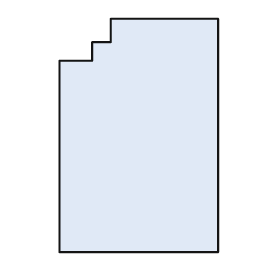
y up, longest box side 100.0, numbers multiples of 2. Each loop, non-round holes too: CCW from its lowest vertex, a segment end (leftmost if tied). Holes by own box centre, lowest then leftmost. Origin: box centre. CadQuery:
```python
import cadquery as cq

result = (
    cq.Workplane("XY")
    .moveTo(-34.0, -50.0)
    .lineTo(34.0, -50.0)
    .lineTo(34.0, 50.0)
    .lineTo(-12.0, 50.0)
    .lineTo(-12.0, 40.0)
    .lineTo(-20.0, 40.0)
    .lineTo(-20.0, 32.0)
    .lineTo(-34.0, 32.0)
    .close()
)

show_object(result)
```